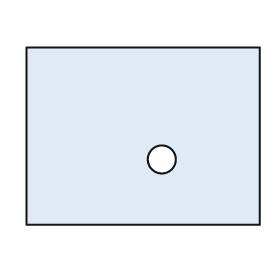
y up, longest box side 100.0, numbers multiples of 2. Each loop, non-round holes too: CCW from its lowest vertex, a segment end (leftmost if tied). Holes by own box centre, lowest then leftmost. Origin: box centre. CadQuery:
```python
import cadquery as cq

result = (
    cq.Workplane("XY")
    .moveTo(-50.0, -38.0)
    .lineTo(50.0, -38.0)
    .lineTo(50.0, 38.0)
    .lineTo(-50.0, 38.0)
    .close()
    .moveTo(8.0, -10.0)
    .circle(6.0)
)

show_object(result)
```